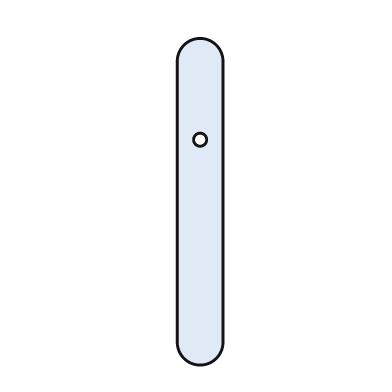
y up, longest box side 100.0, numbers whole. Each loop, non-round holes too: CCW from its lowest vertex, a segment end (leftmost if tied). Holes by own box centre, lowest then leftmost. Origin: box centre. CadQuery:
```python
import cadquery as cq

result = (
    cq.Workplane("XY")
    .moveTo(-7.0, -43.0)
    .threePointArc((0.0, -50.0), (7.0, -43.0))
    .lineTo(7.0, 43.0)
    .threePointArc((0.0, 50.0), (-7.0, 43.0))
    .close()
    .moveTo(0.0, 19.0)
    .circle(2.0)
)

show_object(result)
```